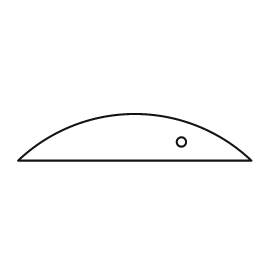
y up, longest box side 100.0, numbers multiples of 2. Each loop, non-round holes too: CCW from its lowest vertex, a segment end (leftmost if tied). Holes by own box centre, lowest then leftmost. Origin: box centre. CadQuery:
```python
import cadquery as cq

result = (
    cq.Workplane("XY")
    .moveTo(-50.0, -10.0)
    .lineTo(50.0, -10.0)
    .threePointArc((0.0, 10.0), (-50.0, -10.0))
    .close()
    .moveTo(20.0, -2.0)
    .circle(2.0)
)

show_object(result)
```